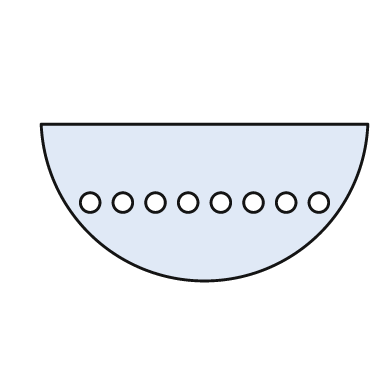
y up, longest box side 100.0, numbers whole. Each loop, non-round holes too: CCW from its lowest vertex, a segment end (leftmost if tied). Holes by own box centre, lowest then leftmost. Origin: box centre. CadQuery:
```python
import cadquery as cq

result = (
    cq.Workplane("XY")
    .moveTo(-50.0, 24.0)
    .threePointArc((0.0, -24.0), (50.0, 24.0))
    .close()
    .moveTo(-35.0, 0.0)
    .circle(3.0)
    .moveTo(-25.0, 0.0)
    .circle(3.0)
    .moveTo(-15.0, 0.0)
    .circle(3.0)
    .moveTo(-5.0, 0.0)
    .circle(3.0)
    .moveTo(5.0, 0.0)
    .circle(3.0)
    .moveTo(15.0, 0.0)
    .circle(3.0)
    .moveTo(25.0, 0.0)
    .circle(3.0)
    .moveTo(35.0, 0.0)
    .circle(3.0)
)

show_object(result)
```